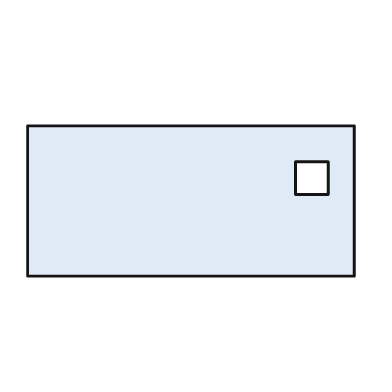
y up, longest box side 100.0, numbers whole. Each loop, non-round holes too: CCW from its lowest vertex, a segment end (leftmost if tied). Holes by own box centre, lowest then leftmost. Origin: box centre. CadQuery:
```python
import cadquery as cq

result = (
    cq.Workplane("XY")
    .moveTo(-50.0, -23.0)
    .lineTo(50.0, -23.0)
    .lineTo(50.0, 23.0)
    .lineTo(-50.0, 23.0)
    .close()
    .moveTo(32.0, 2.0)
    .lineTo(42.0, 2.0)
    .lineTo(42.0, 12.0)
    .lineTo(32.0, 12.0)
    .close()
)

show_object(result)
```